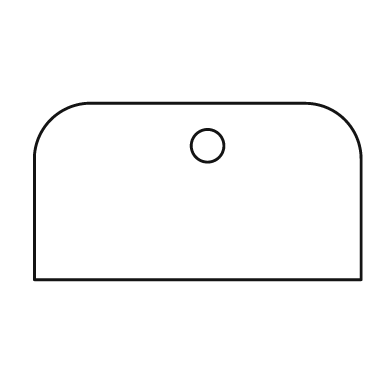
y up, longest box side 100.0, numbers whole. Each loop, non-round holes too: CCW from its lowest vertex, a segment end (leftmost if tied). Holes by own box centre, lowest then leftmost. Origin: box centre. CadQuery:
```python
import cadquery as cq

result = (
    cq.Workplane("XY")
    .moveTo(-50.0, -27.0)
    .lineTo(50.0, -27.0)
    .lineTo(50.0, 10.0)
    .threePointArc((45.0, 22.0), (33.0, 27.0))
    .lineTo(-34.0, 27.0)
    .threePointArc((-45.0, 22.0), (-50.0, 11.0))
    .close()
    .moveTo(3.0, 14.0)
    .circle(5.0)
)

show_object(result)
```